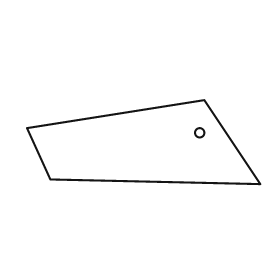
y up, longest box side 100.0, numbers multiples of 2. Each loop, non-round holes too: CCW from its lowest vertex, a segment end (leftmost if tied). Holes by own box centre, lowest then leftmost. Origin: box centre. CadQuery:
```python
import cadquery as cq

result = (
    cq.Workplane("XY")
    .moveTo(50.0, -18.0)
    .lineTo(26.0, 18.0)
    .lineTo(-50.0, 6.0)
    .lineTo(-40.0, -16.0)
    .close()
    .moveTo(24.0, 4.0)
    .circle(2.0)
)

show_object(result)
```